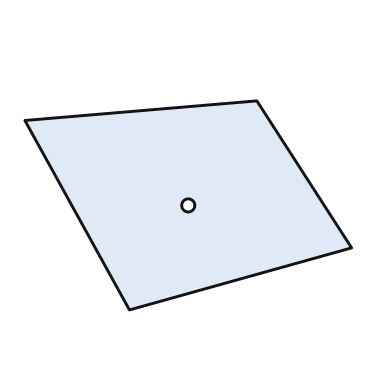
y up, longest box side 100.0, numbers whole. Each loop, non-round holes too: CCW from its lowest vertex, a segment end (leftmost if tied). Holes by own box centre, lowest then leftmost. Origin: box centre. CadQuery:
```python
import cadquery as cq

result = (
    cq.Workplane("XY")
    .moveTo(-18.0, -32.0)
    .lineTo(50.0, -13.0)
    .lineTo(21.0, 32.0)
    .lineTo(-50.0, 26.0)
    .close()
    .moveTo(0.0, 0.0)
    .circle(2.0)
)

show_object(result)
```